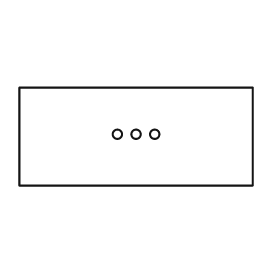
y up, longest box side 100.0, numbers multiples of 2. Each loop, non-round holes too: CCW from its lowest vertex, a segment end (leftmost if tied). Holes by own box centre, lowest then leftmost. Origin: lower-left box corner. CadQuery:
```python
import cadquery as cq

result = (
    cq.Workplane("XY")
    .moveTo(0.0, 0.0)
    .lineTo(100.0, 0.0)
    .lineTo(100.0, 42.0)
    .lineTo(0.0, 42.0)
    .close()
    .moveTo(42.0, 22.0)
    .circle(2.0)
    .moveTo(50.0, 22.0)
    .circle(2.0)
    .moveTo(58.0, 22.0)
    .circle(2.0)
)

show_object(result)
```